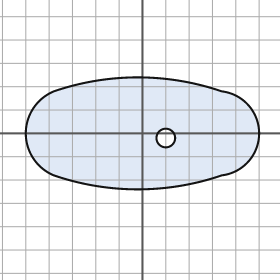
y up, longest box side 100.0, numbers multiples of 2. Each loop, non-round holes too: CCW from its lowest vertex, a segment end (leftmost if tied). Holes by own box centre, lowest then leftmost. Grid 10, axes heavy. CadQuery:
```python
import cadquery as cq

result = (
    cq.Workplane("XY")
    .moveTo(-38.0, -18.0)
    .threePointArc((-2.0, -24.0), (34.0, -18.0))
    .threePointArc((50.0, 0.0), (34.0, 18.0))
    .threePointArc((-2.0, 24.0), (-38.0, 18.0))
    .threePointArc((-50.0, 0.0), (-38.0, -18.0))
    .close()
    .moveTo(10.0, -2.0)
    .circle(4.0)
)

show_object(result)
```